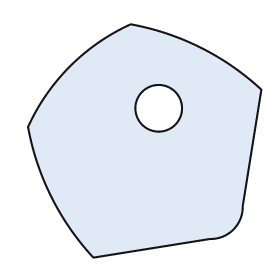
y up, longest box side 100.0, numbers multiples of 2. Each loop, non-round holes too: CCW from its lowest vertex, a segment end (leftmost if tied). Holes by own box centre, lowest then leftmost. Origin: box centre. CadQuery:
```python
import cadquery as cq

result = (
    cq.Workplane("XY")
    .moveTo(-22.0, -50.0)
    .lineTo(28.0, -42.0)
    .threePointArc((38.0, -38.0), (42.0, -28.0))
    .lineTo(50.0, 22.0)
    .threePointArc((24.0, 40.0), (-6.0, 50.0))
    .threePointArc((-32.0, 32.0), (-50.0, 6.0))
    .threePointArc((-40.0, -24.0), (-22.0, -50.0))
    .close()
    .moveTo(6.0, 14.0)
    .circle(10.0)
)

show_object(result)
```